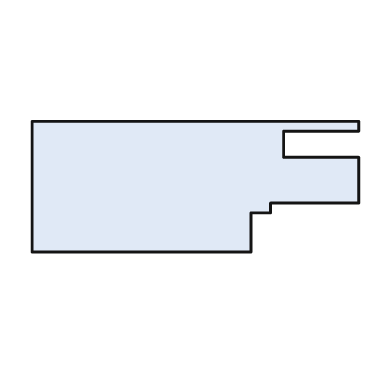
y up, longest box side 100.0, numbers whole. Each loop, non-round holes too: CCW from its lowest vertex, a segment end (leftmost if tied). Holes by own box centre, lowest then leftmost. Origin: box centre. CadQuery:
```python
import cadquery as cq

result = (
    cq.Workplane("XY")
    .moveTo(-50.0, -20.0)
    .lineTo(17.0, -20.0)
    .lineTo(17.0, -8.0)
    .lineTo(23.0, -8.0)
    .lineTo(23.0, -5.0)
    .lineTo(50.0, -5.0)
    .lineTo(50.0, 9.0)
    .lineTo(27.0, 9.0)
    .lineTo(27.0, 17.0)
    .lineTo(50.0, 17.0)
    .lineTo(50.0, 20.0)
    .lineTo(-50.0, 20.0)
    .close()
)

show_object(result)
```